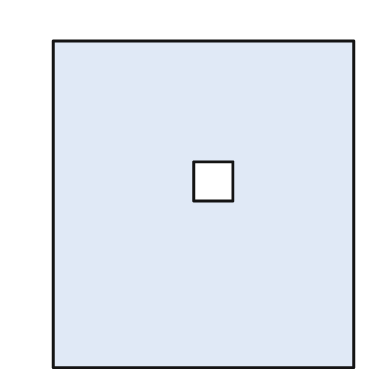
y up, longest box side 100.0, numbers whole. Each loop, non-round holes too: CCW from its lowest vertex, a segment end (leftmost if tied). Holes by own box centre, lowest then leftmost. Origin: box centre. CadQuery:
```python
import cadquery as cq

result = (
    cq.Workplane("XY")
    .moveTo(-46.0, -50.0)
    .lineTo(46.0, -50.0)
    .lineTo(46.0, 50.0)
    .lineTo(-46.0, 50.0)
    .close()
    .moveTo(-3.0, 1.0)
    .lineTo(9.0, 1.0)
    .lineTo(9.0, 13.0)
    .lineTo(-3.0, 13.0)
    .close()
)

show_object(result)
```